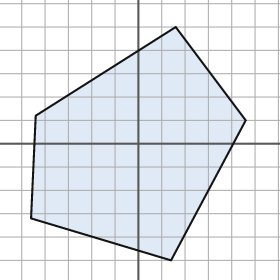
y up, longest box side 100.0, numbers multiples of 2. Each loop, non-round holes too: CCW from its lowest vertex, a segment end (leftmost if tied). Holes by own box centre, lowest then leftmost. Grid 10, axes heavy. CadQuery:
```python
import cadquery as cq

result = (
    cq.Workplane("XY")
    .moveTo(14.0, -50.0)
    .lineTo(46.0, 10.0)
    .lineTo(16.0, 50.0)
    .lineTo(-44.0, 12.0)
    .lineTo(-46.0, -32.0)
    .close()
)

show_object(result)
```